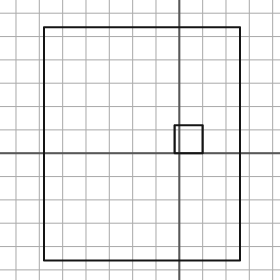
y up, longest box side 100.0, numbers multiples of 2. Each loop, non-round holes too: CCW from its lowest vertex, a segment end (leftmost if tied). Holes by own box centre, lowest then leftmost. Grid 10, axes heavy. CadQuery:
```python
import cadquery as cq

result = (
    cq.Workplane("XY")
    .moveTo(-58.0, -46.0)
    .lineTo(26.0, -46.0)
    .lineTo(26.0, 54.0)
    .lineTo(-58.0, 54.0)
    .close()
    .moveTo(-2.0, 0.0)
    .lineTo(10.0, 0.0)
    .lineTo(10.0, 12.0)
    .lineTo(-2.0, 12.0)
    .close()
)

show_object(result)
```